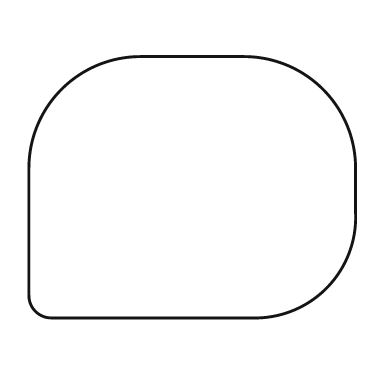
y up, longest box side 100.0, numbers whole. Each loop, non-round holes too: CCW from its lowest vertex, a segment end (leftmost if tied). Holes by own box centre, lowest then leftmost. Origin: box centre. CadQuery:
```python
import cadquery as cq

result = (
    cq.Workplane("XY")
    .moveTo(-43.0, -40.0)
    .lineTo(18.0, -40.0)
    .threePointArc((41.0, -31.0), (50.0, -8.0))
    .lineTo(50.0, 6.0)
    .threePointArc((40.0, 30.0), (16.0, 40.0))
    .lineTo(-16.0, 40.0)
    .threePointArc((-40.0, 30.0), (-50.0, 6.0))
    .lineTo(-50.0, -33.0)
    .threePointArc((-48.0, -38.0), (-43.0, -40.0))
    .close()
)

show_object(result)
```